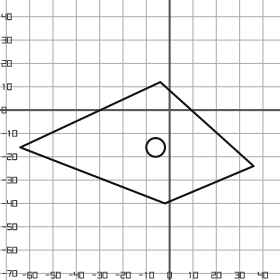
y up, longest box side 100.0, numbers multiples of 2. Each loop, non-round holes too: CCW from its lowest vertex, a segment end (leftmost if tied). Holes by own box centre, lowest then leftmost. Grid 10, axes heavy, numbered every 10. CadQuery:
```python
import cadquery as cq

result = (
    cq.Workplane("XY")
    .moveTo(-2.0, -40.0)
    .lineTo(36.0, -24.0)
    .lineTo(-4.0, 12.0)
    .lineTo(-64.0, -16.0)
    .close()
    .moveTo(-6.0, -16.0)
    .circle(4.0)
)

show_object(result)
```